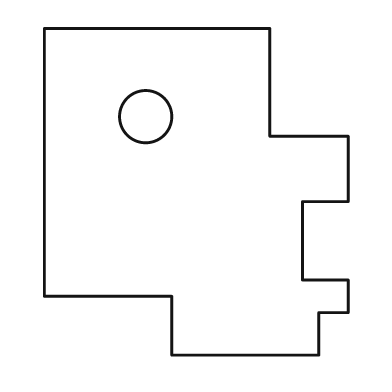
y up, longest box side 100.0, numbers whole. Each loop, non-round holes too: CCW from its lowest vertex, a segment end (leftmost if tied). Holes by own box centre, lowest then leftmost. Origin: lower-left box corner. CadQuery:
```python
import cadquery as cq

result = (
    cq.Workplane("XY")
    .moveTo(39.0, 0.0)
    .lineTo(84.0, 0.0)
    .lineTo(84.0, 13.0)
    .lineTo(93.0, 13.0)
    .lineTo(93.0, 23.0)
    .lineTo(79.0, 23.0)
    .lineTo(79.0, 47.0)
    .lineTo(93.0, 47.0)
    .lineTo(93.0, 67.0)
    .lineTo(69.0, 67.0)
    .lineTo(69.0, 100.0)
    .lineTo(0.0, 100.0)
    .lineTo(0.0, 18.0)
    .lineTo(39.0, 18.0)
    .close()
    .moveTo(31.0, 73.0)
    .circle(8.0)
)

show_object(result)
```